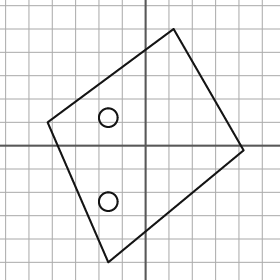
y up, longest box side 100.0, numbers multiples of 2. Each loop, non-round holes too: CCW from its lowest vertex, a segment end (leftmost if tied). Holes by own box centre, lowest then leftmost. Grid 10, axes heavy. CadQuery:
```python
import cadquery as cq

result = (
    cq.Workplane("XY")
    .moveTo(-16.0, -50.0)
    .lineTo(42.0, -2.0)
    .lineTo(12.0, 50.0)
    .lineTo(-42.0, 10.0)
    .close()
    .moveTo(-16.0, -24.0)
    .circle(4.0)
    .moveTo(-16.0, 12.0)
    .circle(4.0)
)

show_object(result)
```